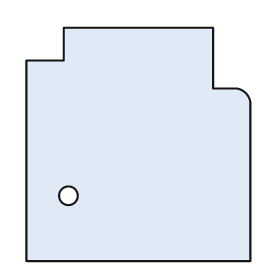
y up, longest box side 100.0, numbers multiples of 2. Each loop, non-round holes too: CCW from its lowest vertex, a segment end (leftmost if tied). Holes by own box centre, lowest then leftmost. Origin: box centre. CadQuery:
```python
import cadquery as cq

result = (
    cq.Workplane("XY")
    .moveTo(-48.0, -50.0)
    .lineTo(48.0, -50.0)
    .lineTo(48.0, 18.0)
    .threePointArc((46.0, 22.0), (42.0, 24.0))
    .lineTo(32.0, 24.0)
    .lineTo(32.0, 50.0)
    .lineTo(-32.0, 50.0)
    .lineTo(-32.0, 36.0)
    .lineTo(-48.0, 36.0)
    .close()
    .moveTo(-30.0, -22.0)
    .circle(4.0)
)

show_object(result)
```